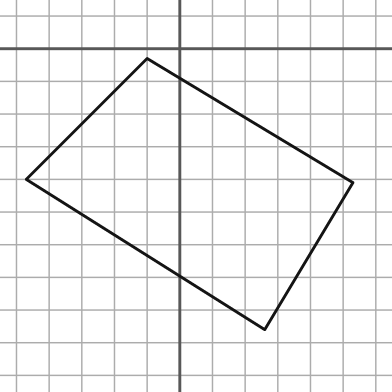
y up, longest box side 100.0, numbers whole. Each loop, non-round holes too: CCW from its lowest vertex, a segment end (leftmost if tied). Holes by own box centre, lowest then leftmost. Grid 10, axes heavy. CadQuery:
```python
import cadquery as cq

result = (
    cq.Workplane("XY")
    .moveTo(26.0, -86.0)
    .lineTo(53.0, -41.0)
    .lineTo(-10.0, -3.0)
    .lineTo(-47.0, -40.0)
    .close()
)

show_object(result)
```